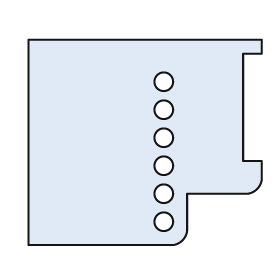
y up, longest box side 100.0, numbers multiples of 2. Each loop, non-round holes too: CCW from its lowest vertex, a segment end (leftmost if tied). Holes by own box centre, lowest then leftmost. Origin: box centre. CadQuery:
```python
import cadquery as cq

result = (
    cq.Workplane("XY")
    .moveTo(-50.0, -44.0)
    .lineTo(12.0, -44.0)
    .threePointArc((16.0, -42.0), (18.0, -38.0))
    .lineTo(18.0, -22.0)
    .lineTo(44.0, -22.0)
    .threePointArc((48.0, -20.0), (50.0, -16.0))
    .lineTo(50.0, -8.0)
    .lineTo(42.0, -8.0)
    .lineTo(42.0, 38.0)
    .lineTo(50.0, 38.0)
    .lineTo(50.0, 44.0)
    .lineTo(-50.0, 44.0)
    .close()
    .moveTo(8.0, -34.0)
    .circle(4.0)
    .moveTo(8.0, -22.0)
    .circle(4.0)
    .moveTo(8.0, -10.0)
    .circle(4.0)
    .moveTo(8.0, 2.0)
    .circle(4.0)
    .moveTo(8.0, 14.0)
    .circle(4.0)
    .moveTo(8.0, 26.0)
    .circle(4.0)
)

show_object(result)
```